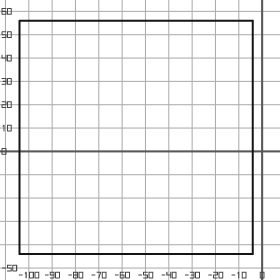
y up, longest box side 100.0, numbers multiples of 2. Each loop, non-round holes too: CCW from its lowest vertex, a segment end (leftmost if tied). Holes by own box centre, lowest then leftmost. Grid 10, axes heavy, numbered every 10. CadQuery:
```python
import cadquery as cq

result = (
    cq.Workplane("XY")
    .moveTo(-104.0, -44.0)
    .lineTo(-4.0, -44.0)
    .lineTo(-4.0, 56.0)
    .lineTo(-104.0, 56.0)
    .close()
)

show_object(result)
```